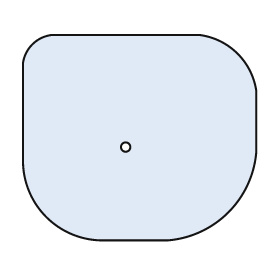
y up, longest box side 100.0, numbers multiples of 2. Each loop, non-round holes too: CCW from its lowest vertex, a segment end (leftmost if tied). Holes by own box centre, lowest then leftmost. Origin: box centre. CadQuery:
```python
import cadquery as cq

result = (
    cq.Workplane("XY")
    .moveTo(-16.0, -44.0)
    .lineTo(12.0, -44.0)
    .threePointArc((38.0, -32.0), (50.0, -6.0))
    .lineTo(50.0, 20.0)
    .threePointArc((42.0, 36.0), (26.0, 44.0))
    .lineTo(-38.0, 44.0)
    .threePointArc((-46.0, 40.0), (-50.0, 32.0))
    .lineTo(-50.0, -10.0)
    .threePointArc((-40.0, -34.0), (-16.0, -44.0))
    .close()
    .moveTo(-6.0, -4.0)
    .circle(2.0)
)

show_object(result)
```